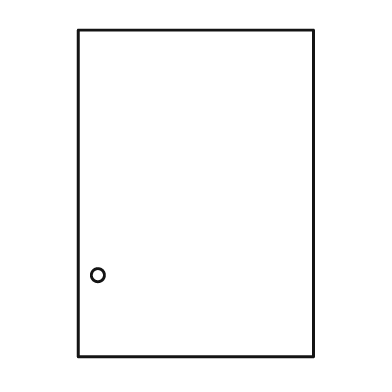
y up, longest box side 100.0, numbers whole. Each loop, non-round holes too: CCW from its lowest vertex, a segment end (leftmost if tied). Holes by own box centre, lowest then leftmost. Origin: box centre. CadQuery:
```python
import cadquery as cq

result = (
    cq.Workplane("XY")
    .moveTo(-36.0, -50.0)
    .lineTo(36.0, -50.0)
    .lineTo(36.0, 50.0)
    .lineTo(-36.0, 50.0)
    .close()
    .moveTo(-30.0, -25.0)
    .circle(2.0)
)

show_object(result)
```